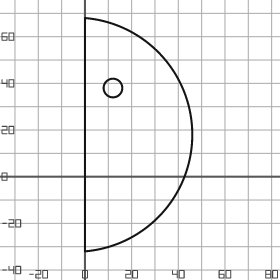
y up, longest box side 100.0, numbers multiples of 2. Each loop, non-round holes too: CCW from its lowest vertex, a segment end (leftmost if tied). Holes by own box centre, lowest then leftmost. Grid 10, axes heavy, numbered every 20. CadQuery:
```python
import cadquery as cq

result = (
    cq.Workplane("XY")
    .moveTo(0.0, -32.0)
    .threePointArc((46.0, 18.0), (0.0, 68.0))
    .close()
    .moveTo(12.0, 38.0)
    .circle(4.0)
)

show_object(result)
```